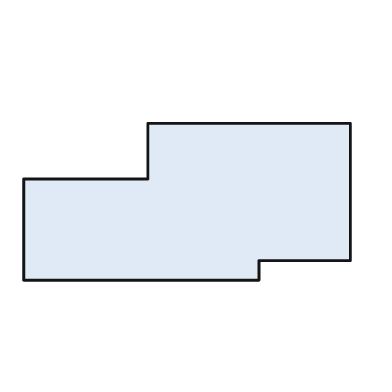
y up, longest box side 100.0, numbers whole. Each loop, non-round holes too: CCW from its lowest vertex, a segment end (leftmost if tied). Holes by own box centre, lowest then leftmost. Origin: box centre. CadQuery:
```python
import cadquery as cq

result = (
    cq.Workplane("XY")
    .moveTo(-50.0, -24.0)
    .lineTo(22.0, -24.0)
    .lineTo(22.0, -18.0)
    .lineTo(50.0, -18.0)
    .lineTo(50.0, 24.0)
    .lineTo(-12.0, 24.0)
    .lineTo(-12.0, 7.0)
    .lineTo(-50.0, 7.0)
    .close()
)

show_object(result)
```